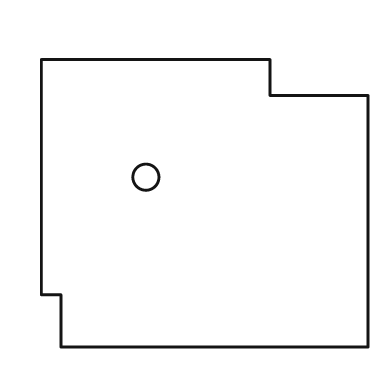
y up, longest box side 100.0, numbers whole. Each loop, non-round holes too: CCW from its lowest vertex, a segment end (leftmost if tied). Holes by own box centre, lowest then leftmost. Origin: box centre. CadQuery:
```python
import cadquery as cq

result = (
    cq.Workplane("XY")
    .moveTo(-44.0, -44.0)
    .lineTo(50.0, -44.0)
    .lineTo(50.0, 33.0)
    .lineTo(20.0, 33.0)
    .lineTo(20.0, 44.0)
    .lineTo(-50.0, 44.0)
    .lineTo(-50.0, -28.0)
    .lineTo(-44.0, -28.0)
    .close()
    .moveTo(-18.0, 8.0)
    .circle(4.0)
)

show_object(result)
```